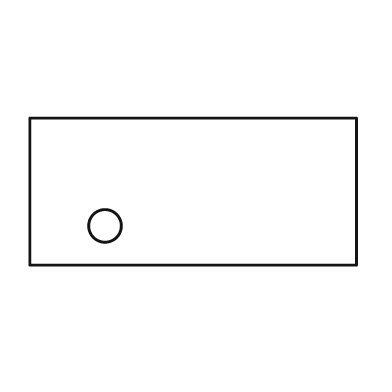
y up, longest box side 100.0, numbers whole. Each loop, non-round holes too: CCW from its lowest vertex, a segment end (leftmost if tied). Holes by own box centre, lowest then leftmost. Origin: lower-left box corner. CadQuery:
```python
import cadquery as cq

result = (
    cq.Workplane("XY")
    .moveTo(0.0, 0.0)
    .lineTo(100.0, 0.0)
    .lineTo(100.0, 45.0)
    .lineTo(0.0, 45.0)
    .close()
    .moveTo(23.0, 12.0)
    .circle(5.0)
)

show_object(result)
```